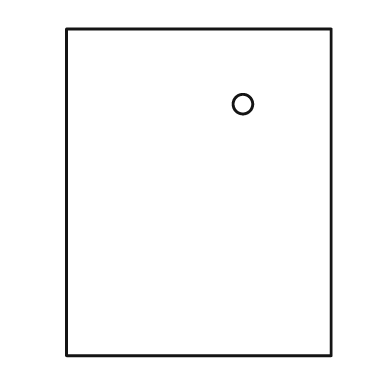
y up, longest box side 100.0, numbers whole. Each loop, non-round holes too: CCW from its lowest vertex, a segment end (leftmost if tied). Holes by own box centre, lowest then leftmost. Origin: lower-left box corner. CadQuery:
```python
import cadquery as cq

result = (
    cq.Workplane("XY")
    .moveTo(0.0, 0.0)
    .lineTo(81.0, 0.0)
    .lineTo(81.0, 100.0)
    .lineTo(0.0, 100.0)
    .close()
    .moveTo(54.0, 77.0)
    .circle(3.0)
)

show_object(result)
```